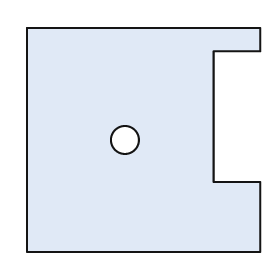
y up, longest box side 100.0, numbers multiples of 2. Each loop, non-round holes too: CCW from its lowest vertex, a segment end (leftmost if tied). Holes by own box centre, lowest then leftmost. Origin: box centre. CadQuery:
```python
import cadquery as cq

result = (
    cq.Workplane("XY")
    .moveTo(-50.0, -48.0)
    .lineTo(50.0, -48.0)
    .lineTo(50.0, -18.0)
    .lineTo(30.0, -18.0)
    .lineTo(30.0, 38.0)
    .lineTo(50.0, 38.0)
    .lineTo(50.0, 48.0)
    .lineTo(-50.0, 48.0)
    .close()
    .moveTo(-8.0, 0.0)
    .circle(6.0)
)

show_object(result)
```